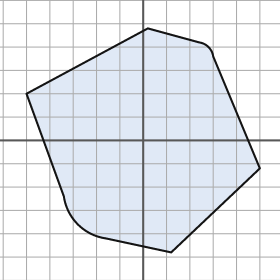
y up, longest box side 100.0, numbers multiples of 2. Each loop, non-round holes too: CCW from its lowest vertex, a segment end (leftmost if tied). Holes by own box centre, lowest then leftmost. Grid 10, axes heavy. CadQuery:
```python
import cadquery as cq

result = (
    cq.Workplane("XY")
    .moveTo(12.0, -48.0)
    .lineTo(50.0, -12.0)
    .lineTo(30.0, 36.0)
    .threePointArc((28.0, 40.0), (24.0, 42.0))
    .lineTo(2.0, 48.0)
    .lineTo(-50.0, 20.0)
    .lineTo(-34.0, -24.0)
    .threePointArc((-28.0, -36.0), (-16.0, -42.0))
    .close()
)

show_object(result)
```